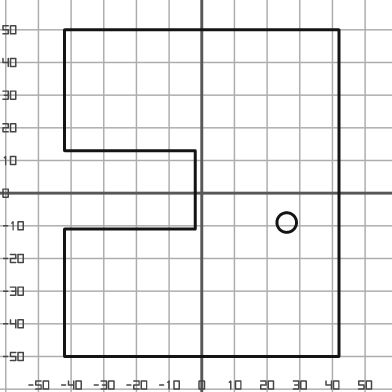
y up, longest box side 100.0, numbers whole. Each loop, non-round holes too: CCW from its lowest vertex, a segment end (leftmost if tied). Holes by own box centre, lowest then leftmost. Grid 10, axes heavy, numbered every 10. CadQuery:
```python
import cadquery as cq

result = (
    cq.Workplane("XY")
    .moveTo(-42.0, -50.0)
    .lineTo(42.0, -50.0)
    .lineTo(42.0, 50.0)
    .lineTo(-42.0, 50.0)
    .lineTo(-42.0, 13.0)
    .lineTo(-2.0, 13.0)
    .lineTo(-2.0, -11.0)
    .lineTo(-42.0, -11.0)
    .close()
    .moveTo(26.0, -9.0)
    .circle(3.0)
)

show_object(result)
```